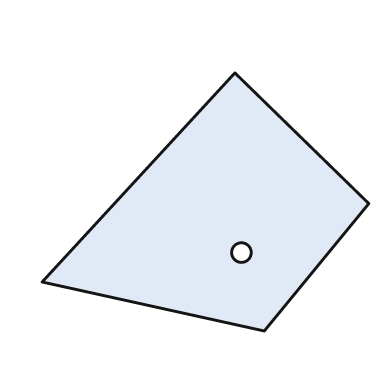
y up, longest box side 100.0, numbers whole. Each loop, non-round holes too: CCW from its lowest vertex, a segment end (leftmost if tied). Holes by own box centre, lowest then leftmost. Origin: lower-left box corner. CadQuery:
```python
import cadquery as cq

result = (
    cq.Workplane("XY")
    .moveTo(68.0, 0.0)
    .lineTo(100.0, 39.0)
    .lineTo(59.0, 79.0)
    .lineTo(0.0, 15.0)
    .close()
    .moveTo(61.0, 24.0)
    .circle(3.0)
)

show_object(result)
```